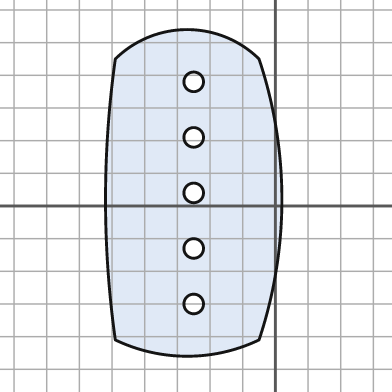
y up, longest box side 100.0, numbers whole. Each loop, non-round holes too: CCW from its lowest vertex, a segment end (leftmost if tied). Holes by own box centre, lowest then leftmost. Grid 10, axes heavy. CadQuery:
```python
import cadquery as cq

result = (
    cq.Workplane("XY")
    .moveTo(-49.0, -41.0)
    .threePointArc((-27.0, -46.0), (-5.0, -41.0))
    .threePointArc((2.0, 2.0), (-5.0, 45.0))
    .threePointArc((-27.0, 54.0), (-49.0, 45.0))
    .threePointArc((-52.0, 2.0), (-49.0, -41.0))
    .close()
    .moveTo(-25.0, -30.0)
    .circle(3.0)
    .moveTo(-25.0, -13.0)
    .circle(3.0)
    .moveTo(-25.0, 4.0)
    .circle(3.0)
    .moveTo(-25.0, 21.0)
    .circle(3.0)
    .moveTo(-25.0, 38.0)
    .circle(3.0)
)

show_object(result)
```